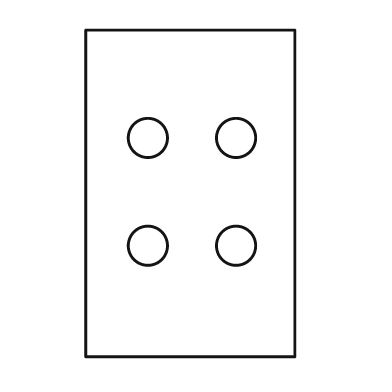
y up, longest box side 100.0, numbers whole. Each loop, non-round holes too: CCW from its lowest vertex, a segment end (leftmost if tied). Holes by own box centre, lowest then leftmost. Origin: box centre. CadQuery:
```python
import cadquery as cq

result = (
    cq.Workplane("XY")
    .moveTo(-32.0, -50.0)
    .lineTo(32.0, -50.0)
    .lineTo(32.0, 50.0)
    .lineTo(-32.0, 50.0)
    .close()
    .moveTo(-13.0, -16.0)
    .circle(6.0)
    .moveTo(14.0, -16.0)
    .circle(6.0)
    .moveTo(-13.0, 17.0)
    .circle(6.0)
    .moveTo(14.0, 17.0)
    .circle(6.0)
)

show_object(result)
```